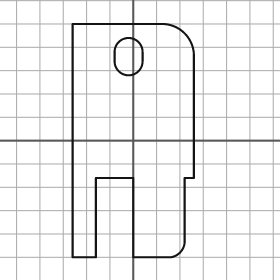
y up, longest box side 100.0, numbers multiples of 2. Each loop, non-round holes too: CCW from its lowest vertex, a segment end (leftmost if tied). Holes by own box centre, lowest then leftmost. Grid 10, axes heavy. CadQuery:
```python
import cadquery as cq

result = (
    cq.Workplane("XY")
    .moveTo(-26.0, -50.0)
    .lineTo(-16.0, -50.0)
    .lineTo(-16.0, -16.0)
    .lineTo(0.0, -16.0)
    .lineTo(0.0, -50.0)
    .lineTo(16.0, -50.0)
    .threePointArc((20.0, -48.0), (22.0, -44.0))
    .lineTo(22.0, -16.0)
    .lineTo(26.0, -16.0)
    .lineTo(26.0, 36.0)
    .threePointArc((22.0, 46.0), (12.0, 50.0))
    .lineTo(-26.0, 50.0)
    .close()
    .moveTo(-8.0, 34.0)
    .threePointArc((-2.0, 28.0), (4.0, 34.0))
    .lineTo(4.0, 38.0)
    .threePointArc((-2.0, 44.0), (-8.0, 38.0))
    .close()
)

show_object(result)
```